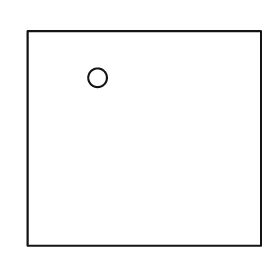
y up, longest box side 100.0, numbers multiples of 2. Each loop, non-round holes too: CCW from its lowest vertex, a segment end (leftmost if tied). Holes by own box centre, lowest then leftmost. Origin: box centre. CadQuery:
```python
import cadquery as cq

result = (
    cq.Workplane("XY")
    .moveTo(-50.0, -46.0)
    .lineTo(50.0, -46.0)
    .lineTo(50.0, 46.0)
    .lineTo(-50.0, 46.0)
    .close()
    .moveTo(-20.0, 26.0)
    .circle(4.0)
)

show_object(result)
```